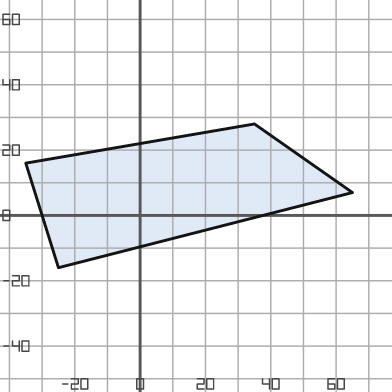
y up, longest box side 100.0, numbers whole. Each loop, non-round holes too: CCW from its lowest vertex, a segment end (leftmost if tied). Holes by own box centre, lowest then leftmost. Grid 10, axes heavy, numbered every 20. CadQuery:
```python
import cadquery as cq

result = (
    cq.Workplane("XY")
    .moveTo(-25.0, -16.0)
    .lineTo(65.0, 7.0)
    .lineTo(35.0, 28.0)
    .lineTo(-35.0, 16.0)
    .close()
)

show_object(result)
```